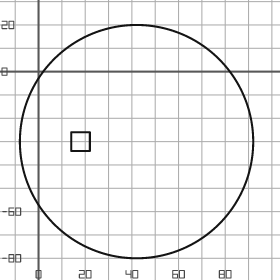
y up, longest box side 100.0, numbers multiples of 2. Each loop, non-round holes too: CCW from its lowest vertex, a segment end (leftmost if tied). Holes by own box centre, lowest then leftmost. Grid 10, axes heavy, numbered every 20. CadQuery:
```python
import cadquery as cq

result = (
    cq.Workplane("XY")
    .moveTo(42.0, -30.0)
    .circle(50.0)
    .moveTo(14.0, -34.0)
    .lineTo(22.0, -34.0)
    .lineTo(22.0, -26.0)
    .lineTo(14.0, -26.0)
    .close()
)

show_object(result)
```